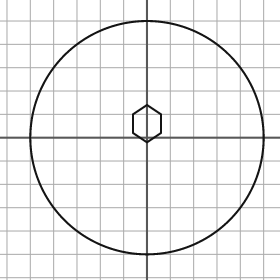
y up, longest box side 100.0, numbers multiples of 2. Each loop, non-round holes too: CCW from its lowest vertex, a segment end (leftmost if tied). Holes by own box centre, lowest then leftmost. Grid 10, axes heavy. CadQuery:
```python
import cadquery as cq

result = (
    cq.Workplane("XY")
    .moveTo(0.0, 0.0)
    .circle(50.0)
    .moveTo(0.0, -2.0)
    .lineTo(6.0, 2.0)
    .lineTo(6.0, 10.0)
    .lineTo(0.0, 14.0)
    .lineTo(-6.0, 10.0)
    .lineTo(-6.0, 2.0)
    .close()
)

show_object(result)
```